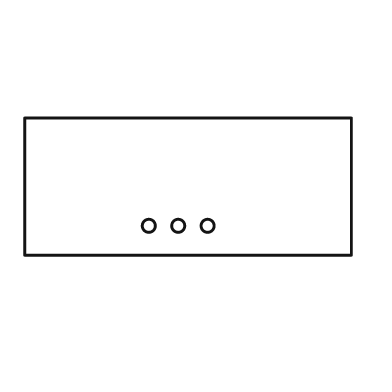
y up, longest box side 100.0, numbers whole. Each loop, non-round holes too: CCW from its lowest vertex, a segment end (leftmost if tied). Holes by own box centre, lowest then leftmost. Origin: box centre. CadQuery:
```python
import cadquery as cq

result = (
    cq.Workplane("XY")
    .moveTo(-50.0, -21.0)
    .lineTo(50.0, -21.0)
    .lineTo(50.0, 21.0)
    .lineTo(-50.0, 21.0)
    .close()
    .moveTo(-12.0, -12.0)
    .circle(2.0)
    .moveTo(-3.0, -12.0)
    .circle(2.0)
    .moveTo(6.0, -12.0)
    .circle(2.0)
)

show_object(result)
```